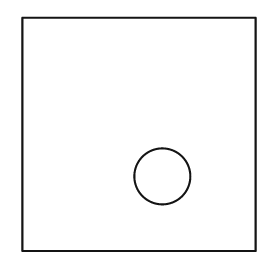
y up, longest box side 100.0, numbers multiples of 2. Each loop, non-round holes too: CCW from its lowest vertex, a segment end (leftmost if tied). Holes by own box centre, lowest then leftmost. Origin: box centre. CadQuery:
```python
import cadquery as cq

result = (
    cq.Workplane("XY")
    .moveTo(-50.0, -50.0)
    .lineTo(50.0, -50.0)
    .lineTo(50.0, 50.0)
    .lineTo(-50.0, 50.0)
    .close()
    .moveTo(10.0, -18.0)
    .circle(12.0)
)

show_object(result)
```